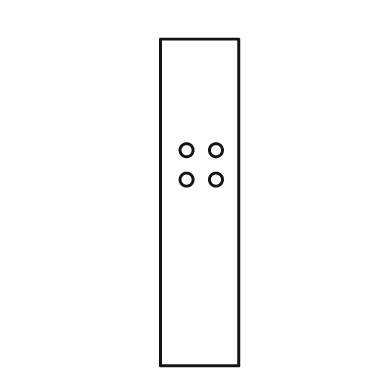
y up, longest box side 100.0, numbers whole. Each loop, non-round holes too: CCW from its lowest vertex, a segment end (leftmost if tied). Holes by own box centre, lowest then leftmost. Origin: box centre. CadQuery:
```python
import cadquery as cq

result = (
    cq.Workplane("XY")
    .moveTo(-12.0, -50.0)
    .lineTo(12.0, -50.0)
    .lineTo(12.0, 50.0)
    .lineTo(-12.0, 50.0)
    .close()
    .moveTo(-4.0, 7.0)
    .circle(2.0)
    .moveTo(5.0, 7.0)
    .circle(2.0)
    .moveTo(-4.0, 16.0)
    .circle(2.0)
    .moveTo(5.0, 16.0)
    .circle(2.0)
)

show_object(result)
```